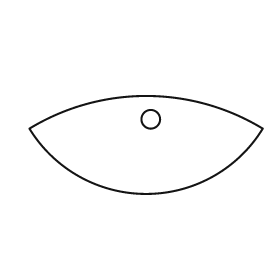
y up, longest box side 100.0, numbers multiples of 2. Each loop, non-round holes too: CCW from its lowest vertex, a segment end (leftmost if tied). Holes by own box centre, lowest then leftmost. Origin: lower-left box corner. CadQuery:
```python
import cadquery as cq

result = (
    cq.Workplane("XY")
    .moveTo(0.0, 28.0)
    .threePointArc((50.0, 0.0), (100.0, 28.0))
    .threePointArc((50.0, 42.0), (0.0, 28.0))
    .close()
    .moveTo(52.0, 32.0)
    .circle(4.0)
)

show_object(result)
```